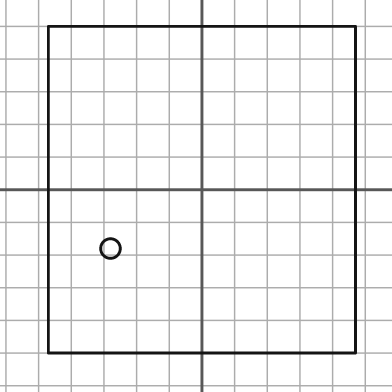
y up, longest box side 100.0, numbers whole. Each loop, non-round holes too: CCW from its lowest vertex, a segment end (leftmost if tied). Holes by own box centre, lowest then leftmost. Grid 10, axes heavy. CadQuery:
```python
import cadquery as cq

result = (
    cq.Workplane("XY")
    .moveTo(-47.0, -50.0)
    .lineTo(47.0, -50.0)
    .lineTo(47.0, 50.0)
    .lineTo(-47.0, 50.0)
    .close()
    .moveTo(-28.0, -18.0)
    .circle(3.0)
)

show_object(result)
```